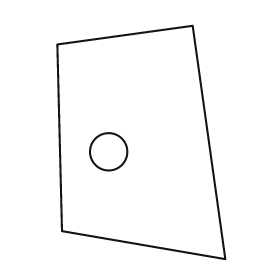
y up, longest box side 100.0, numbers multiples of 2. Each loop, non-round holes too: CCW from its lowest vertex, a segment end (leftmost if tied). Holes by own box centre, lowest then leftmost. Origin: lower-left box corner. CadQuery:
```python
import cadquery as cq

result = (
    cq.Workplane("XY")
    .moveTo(72.0, 0.0)
    .lineTo(58.0, 100.0)
    .lineTo(0.0, 92.0)
    .lineTo(2.0, 12.0)
    .close()
    .moveTo(22.0, 46.0)
    .circle(8.0)
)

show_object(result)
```